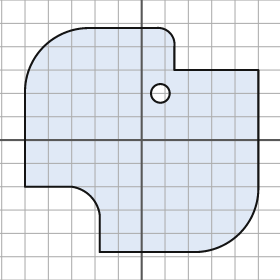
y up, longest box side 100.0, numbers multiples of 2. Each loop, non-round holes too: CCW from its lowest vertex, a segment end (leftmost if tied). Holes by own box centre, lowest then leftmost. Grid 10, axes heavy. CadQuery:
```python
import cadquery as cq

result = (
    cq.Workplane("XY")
    .moveTo(-18.0, -48.0)
    .lineTo(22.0, -48.0)
    .threePointArc((42.0, -40.0), (50.0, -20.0))
    .lineTo(50.0, 30.0)
    .lineTo(14.0, 30.0)
    .lineTo(14.0, 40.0)
    .threePointArc((12.0, 46.0), (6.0, 48.0))
    .lineTo(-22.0, 48.0)
    .threePointArc((-42.0, 40.0), (-50.0, 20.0))
    .lineTo(-50.0, -20.0)
    .lineTo(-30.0, -20.0)
    .threePointArc((-22.0, -24.0), (-18.0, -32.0))
    .close()
    .moveTo(8.0, 20.0)
    .circle(4.0)
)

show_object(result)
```